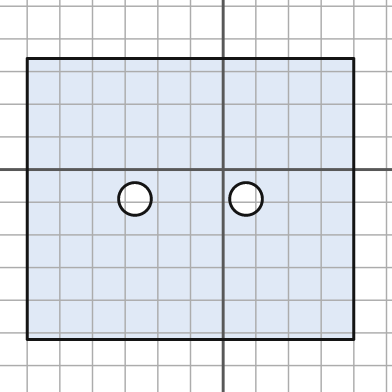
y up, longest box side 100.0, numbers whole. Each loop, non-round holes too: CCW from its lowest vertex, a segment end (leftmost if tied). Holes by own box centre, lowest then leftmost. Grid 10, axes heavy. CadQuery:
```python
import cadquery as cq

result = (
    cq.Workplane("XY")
    .moveTo(-60.0, -52.0)
    .lineTo(40.0, -52.0)
    .lineTo(40.0, 34.0)
    .lineTo(-60.0, 34.0)
    .close()
    .moveTo(-27.0, -9.0)
    .circle(5.0)
    .moveTo(7.0, -9.0)
    .circle(5.0)
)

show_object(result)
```